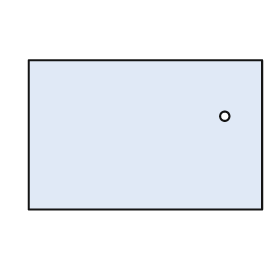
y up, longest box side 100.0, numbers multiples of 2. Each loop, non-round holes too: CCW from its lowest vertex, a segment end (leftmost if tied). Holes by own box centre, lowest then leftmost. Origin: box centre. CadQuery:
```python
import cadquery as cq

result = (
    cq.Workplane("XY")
    .moveTo(-50.0, -32.0)
    .lineTo(50.0, -32.0)
    .lineTo(50.0, 32.0)
    .lineTo(-50.0, 32.0)
    .close()
    .moveTo(34.0, 8.0)
    .circle(2.0)
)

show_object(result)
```